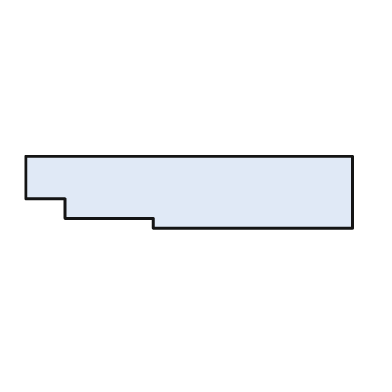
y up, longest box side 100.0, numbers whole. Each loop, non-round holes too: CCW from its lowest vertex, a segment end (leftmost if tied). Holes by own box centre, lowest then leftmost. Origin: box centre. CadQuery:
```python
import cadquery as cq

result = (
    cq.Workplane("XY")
    .moveTo(-11.0, -11.0)
    .lineTo(50.0, -11.0)
    .lineTo(50.0, 11.0)
    .lineTo(-50.0, 11.0)
    .lineTo(-50.0, -2.0)
    .lineTo(-38.0, -2.0)
    .lineTo(-38.0, -8.0)
    .lineTo(-11.0, -8.0)
    .close()
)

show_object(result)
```